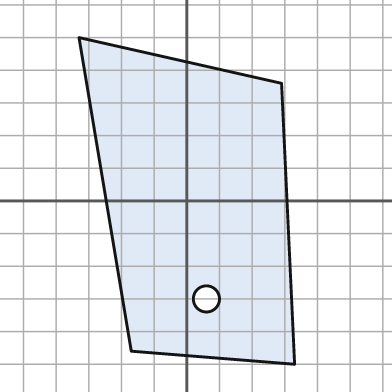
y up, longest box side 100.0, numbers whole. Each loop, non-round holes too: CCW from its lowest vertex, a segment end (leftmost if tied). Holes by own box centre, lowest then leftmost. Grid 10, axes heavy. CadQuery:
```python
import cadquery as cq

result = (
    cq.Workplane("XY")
    .moveTo(33.0, -50.0)
    .lineTo(29.0, 36.0)
    .lineTo(-33.0, 50.0)
    .lineTo(-17.0, -46.0)
    .close()
    .moveTo(6.0, -30.0)
    .circle(4.0)
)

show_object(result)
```